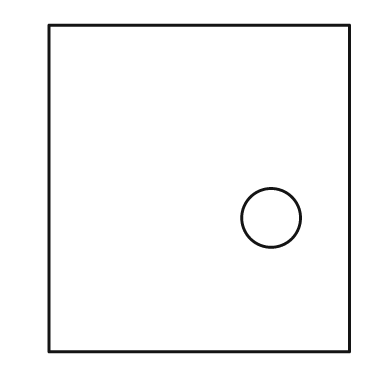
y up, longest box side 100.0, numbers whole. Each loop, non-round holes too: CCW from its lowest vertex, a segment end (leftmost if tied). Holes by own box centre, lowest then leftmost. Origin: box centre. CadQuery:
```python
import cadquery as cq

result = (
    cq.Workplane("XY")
    .moveTo(-46.0, -50.0)
    .lineTo(46.0, -50.0)
    .lineTo(46.0, 50.0)
    .lineTo(-46.0, 50.0)
    .close()
    .moveTo(22.0, -9.0)
    .circle(9.0)
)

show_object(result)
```